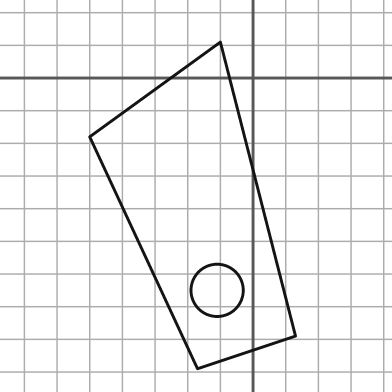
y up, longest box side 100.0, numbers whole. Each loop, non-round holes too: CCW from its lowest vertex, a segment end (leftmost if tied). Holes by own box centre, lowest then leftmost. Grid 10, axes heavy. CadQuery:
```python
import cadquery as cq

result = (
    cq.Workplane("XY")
    .moveTo(-17.0, -89.0)
    .lineTo(13.0, -79.0)
    .lineTo(-10.0, 11.0)
    .lineTo(-50.0, -18.0)
    .close()
    .moveTo(-11.0, -65.0)
    .circle(8.0)
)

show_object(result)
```